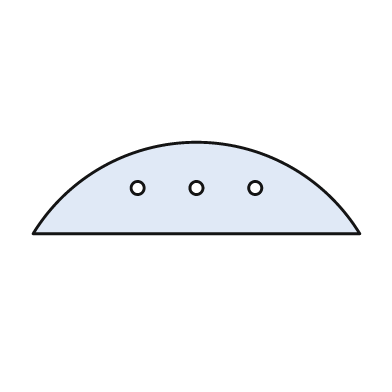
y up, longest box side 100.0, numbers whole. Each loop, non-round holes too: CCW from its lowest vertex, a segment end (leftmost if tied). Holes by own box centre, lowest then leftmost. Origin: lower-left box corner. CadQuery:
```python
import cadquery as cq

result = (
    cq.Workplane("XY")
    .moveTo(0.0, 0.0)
    .lineTo(100.0, 0.0)
    .threePointArc((50.0, 28.0), (0.0, 0.0))
    .close()
    .moveTo(32.0, 14.0)
    .circle(2.0)
    .moveTo(50.0, 14.0)
    .circle(2.0)
    .moveTo(68.0, 14.0)
    .circle(2.0)
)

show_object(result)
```